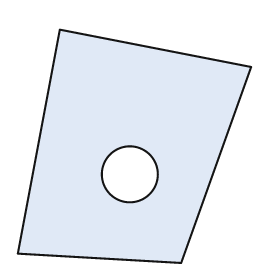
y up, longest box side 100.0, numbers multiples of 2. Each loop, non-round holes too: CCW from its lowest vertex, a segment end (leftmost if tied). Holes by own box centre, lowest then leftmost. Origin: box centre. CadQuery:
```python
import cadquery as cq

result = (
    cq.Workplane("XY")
    .moveTo(20.0, -50.0)
    .lineTo(50.0, 34.0)
    .lineTo(-32.0, 50.0)
    .lineTo(-50.0, -46.0)
    .close()
    .moveTo(-2.0, -12.0)
    .circle(12.0)
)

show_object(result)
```